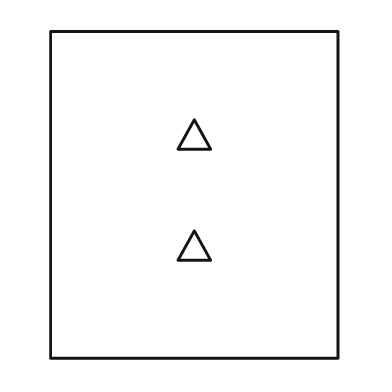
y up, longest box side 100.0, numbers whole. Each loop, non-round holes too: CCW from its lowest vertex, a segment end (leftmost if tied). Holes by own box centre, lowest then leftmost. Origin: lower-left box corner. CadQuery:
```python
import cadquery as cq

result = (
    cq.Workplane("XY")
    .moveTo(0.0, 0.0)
    .lineTo(88.0, 0.0)
    .lineTo(88.0, 100.0)
    .lineTo(0.0, 100.0)
    .close()
    .moveTo(39.0, 30.0)
    .lineTo(49.0, 30.0)
    .lineTo(44.0, 39.0)
    .close()
    .moveTo(39.0, 64.0)
    .lineTo(49.0, 64.0)
    .lineTo(44.0, 73.0)
    .close()
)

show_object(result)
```